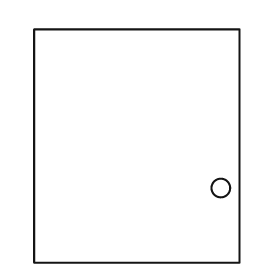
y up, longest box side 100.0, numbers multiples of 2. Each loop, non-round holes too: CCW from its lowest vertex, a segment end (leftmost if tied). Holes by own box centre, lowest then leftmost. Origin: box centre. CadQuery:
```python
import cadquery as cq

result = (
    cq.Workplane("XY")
    .moveTo(-44.0, -50.0)
    .lineTo(44.0, -50.0)
    .lineTo(44.0, 50.0)
    .lineTo(-44.0, 50.0)
    .close()
    .moveTo(36.0, -18.0)
    .circle(4.0)
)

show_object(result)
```